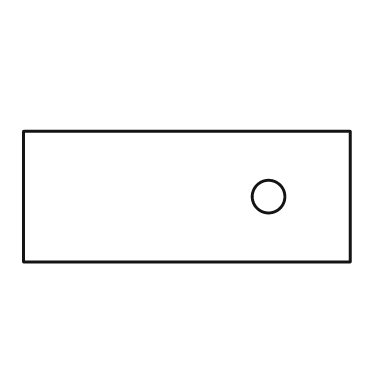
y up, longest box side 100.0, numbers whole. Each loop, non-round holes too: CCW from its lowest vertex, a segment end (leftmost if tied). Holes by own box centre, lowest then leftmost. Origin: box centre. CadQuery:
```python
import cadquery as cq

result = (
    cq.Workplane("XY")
    .moveTo(-50.0, -20.0)
    .lineTo(50.0, -20.0)
    .lineTo(50.0, 20.0)
    .lineTo(-50.0, 20.0)
    .close()
    .moveTo(25.0, 0.0)
    .circle(5.0)
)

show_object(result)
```